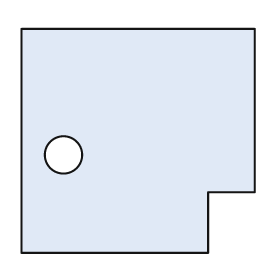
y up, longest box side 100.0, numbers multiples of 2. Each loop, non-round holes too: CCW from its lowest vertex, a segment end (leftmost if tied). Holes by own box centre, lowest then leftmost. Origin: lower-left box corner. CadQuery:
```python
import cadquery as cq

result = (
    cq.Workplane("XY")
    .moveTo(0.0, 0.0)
    .lineTo(80.0, 0.0)
    .lineTo(80.0, 26.0)
    .lineTo(100.0, 26.0)
    .lineTo(100.0, 96.0)
    .lineTo(0.0, 96.0)
    .close()
    .moveTo(18.0, 42.0)
    .circle(8.0)
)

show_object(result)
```